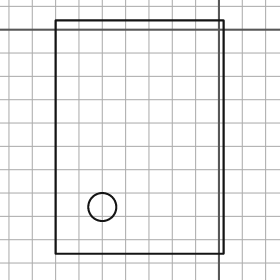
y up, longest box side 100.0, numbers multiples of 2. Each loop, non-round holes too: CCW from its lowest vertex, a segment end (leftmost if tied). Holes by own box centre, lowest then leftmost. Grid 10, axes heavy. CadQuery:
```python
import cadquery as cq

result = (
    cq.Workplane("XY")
    .moveTo(-70.0, -96.0)
    .lineTo(2.0, -96.0)
    .lineTo(2.0, 4.0)
    .lineTo(-70.0, 4.0)
    .close()
    .moveTo(-50.0, -76.0)
    .circle(6.0)
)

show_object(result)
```